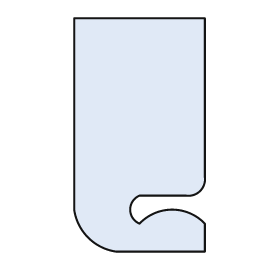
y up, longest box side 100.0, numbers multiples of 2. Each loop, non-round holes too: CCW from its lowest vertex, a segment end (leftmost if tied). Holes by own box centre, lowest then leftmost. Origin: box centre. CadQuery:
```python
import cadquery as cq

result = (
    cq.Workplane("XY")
    .moveTo(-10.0, -50.0)
    .lineTo(28.0, -50.0)
    .lineTo(28.0, -38.0)
    .threePointArc((14.0, -32.0), (0.0, -38.0))
    .threePointArc((-4.0, -32.0), (0.0, -26.0))
    .lineTo(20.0, -26.0)
    .threePointArc((26.0, -24.0), (28.0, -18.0))
    .lineTo(28.0, 50.0)
    .lineTo(-28.0, 50.0)
    .lineTo(-28.0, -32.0)
    .threePointArc((-22.0, -44.0), (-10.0, -50.0))
    .close()
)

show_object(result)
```